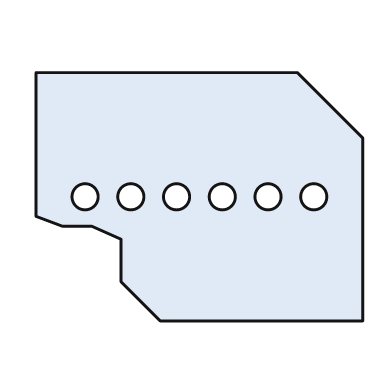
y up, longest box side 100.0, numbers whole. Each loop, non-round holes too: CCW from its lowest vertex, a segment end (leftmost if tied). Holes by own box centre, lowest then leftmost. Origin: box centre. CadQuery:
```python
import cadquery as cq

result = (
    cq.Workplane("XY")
    .moveTo(-12.0, -38.0)
    .lineTo(50.0, -38.0)
    .lineTo(50.0, 18.0)
    .lineTo(30.0, 38.0)
    .lineTo(-50.0, 38.0)
    .lineTo(-50.0, -6.0)
    .lineTo(-42.0, -9.0)
    .lineTo(-33.0, -9.0)
    .lineTo(-24.0, -13.0)
    .lineTo(-24.0, -26.0)
    .close()
    .moveTo(-35.0, 0.0)
    .circle(4.0)
    .moveTo(-21.0, 0.0)
    .circle(4.0)
    .moveTo(-7.0, 0.0)
    .circle(4.0)
    .moveTo(7.0, 0.0)
    .circle(4.0)
    .moveTo(21.0, 0.0)
    .circle(4.0)
    .moveTo(35.0, 0.0)
    .circle(4.0)
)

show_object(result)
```